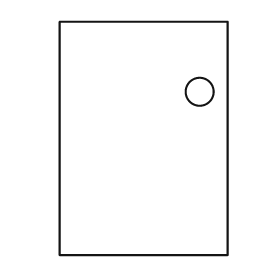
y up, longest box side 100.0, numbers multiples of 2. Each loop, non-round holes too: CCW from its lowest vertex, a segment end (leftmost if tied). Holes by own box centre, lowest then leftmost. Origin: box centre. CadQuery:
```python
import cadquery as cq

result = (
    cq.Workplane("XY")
    .moveTo(-36.0, -50.0)
    .lineTo(36.0, -50.0)
    .lineTo(36.0, 50.0)
    .lineTo(-36.0, 50.0)
    .close()
    .moveTo(24.0, 20.0)
    .circle(6.0)
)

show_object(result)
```